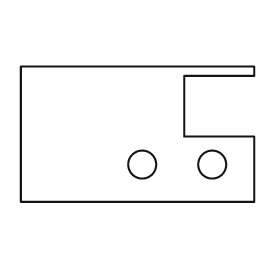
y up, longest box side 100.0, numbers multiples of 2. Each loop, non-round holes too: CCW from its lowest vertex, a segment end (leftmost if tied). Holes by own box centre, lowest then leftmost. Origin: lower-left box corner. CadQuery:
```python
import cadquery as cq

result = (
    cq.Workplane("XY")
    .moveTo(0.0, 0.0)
    .lineTo(100.0, 0.0)
    .lineTo(100.0, 28.0)
    .lineTo(70.0, 28.0)
    .lineTo(70.0, 54.0)
    .lineTo(100.0, 54.0)
    .lineTo(100.0, 58.0)
    .lineTo(0.0, 58.0)
    .close()
    .moveTo(52.0, 16.0)
    .circle(6.0)
    .moveTo(82.0, 16.0)
    .circle(6.0)
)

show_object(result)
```